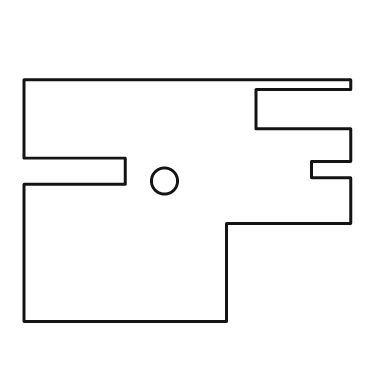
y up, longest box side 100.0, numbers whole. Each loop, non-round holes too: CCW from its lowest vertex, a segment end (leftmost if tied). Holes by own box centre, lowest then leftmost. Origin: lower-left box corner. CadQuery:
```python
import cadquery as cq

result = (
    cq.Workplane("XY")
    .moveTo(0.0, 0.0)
    .lineTo(62.0, 0.0)
    .lineTo(62.0, 30.0)
    .lineTo(100.0, 30.0)
    .lineTo(100.0, 44.0)
    .lineTo(88.0, 44.0)
    .lineTo(88.0, 49.0)
    .lineTo(100.0, 49.0)
    .lineTo(100.0, 59.0)
    .lineTo(71.0, 59.0)
    .lineTo(71.0, 71.0)
    .lineTo(100.0, 71.0)
    .lineTo(100.0, 74.0)
    .lineTo(0.0, 74.0)
    .lineTo(0.0, 50.0)
    .lineTo(31.0, 50.0)
    .lineTo(31.0, 42.0)
    .lineTo(0.0, 42.0)
    .close()
    .moveTo(43.0, 43.0)
    .circle(4.0)
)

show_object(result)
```